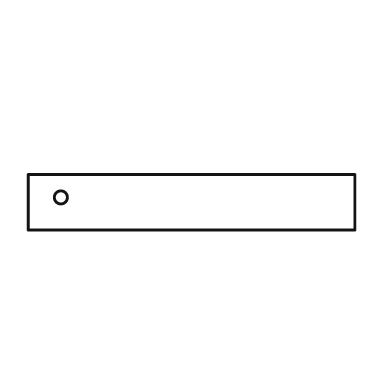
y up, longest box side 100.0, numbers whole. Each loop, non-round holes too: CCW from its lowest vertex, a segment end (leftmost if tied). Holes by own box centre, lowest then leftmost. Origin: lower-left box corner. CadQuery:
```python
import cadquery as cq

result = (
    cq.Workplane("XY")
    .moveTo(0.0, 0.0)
    .lineTo(100.0, 0.0)
    .lineTo(100.0, 17.0)
    .lineTo(0.0, 17.0)
    .close()
    .moveTo(10.0, 10.0)
    .circle(2.0)
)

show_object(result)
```